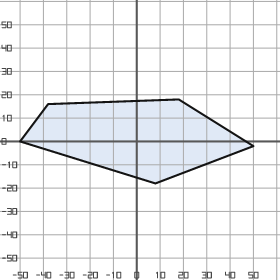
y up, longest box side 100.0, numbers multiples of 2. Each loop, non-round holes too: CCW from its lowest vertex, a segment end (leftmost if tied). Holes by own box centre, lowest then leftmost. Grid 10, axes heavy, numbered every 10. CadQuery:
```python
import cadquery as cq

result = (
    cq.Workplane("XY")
    .moveTo(8.0, -18.0)
    .lineTo(50.0, -2.0)
    .lineTo(18.0, 18.0)
    .lineTo(-38.0, 16.0)
    .lineTo(-50.0, 0.0)
    .close()
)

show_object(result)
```